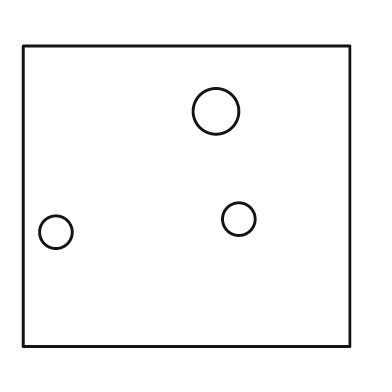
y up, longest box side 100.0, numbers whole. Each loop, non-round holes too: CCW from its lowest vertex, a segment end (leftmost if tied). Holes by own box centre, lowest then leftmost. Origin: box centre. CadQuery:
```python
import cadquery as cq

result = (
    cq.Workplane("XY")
    .moveTo(-50.0, -46.0)
    .lineTo(50.0, -46.0)
    .lineTo(50.0, 46.0)
    .lineTo(-50.0, 46.0)
    .close()
    .moveTo(-40.0, -11.0)
    .circle(5.0)
    .moveTo(16.0, -7.0)
    .circle(5.0)
    .moveTo(9.0, 26.0)
    .circle(7.0)
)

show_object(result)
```